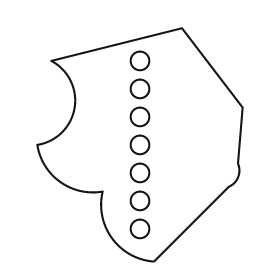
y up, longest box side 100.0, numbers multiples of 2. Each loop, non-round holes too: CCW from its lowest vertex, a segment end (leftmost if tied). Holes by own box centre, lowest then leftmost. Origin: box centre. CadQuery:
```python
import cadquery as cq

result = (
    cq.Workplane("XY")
    .moveTo(6.0, -50.0)
    .lineTo(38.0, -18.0)
    .threePointArc((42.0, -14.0), (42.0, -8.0))
    .lineTo(44.0, 16.0)
    .lineTo(18.0, 50.0)
    .lineTo(-38.0, 36.0)
    .threePointArc((-28.0, 16.0), (-44.0, 0.0))
    .threePointArc((-34.0, -16.0), (-16.0, -20.0))
    .threePointArc((-12.0, -40.0), (6.0, -50.0))
    .close()
    .moveTo(0.0, -36.0)
    .circle(4.0)
    .moveTo(0.0, -24.0)
    .circle(4.0)
    .moveTo(0.0, -12.0)
    .circle(4.0)
    .moveTo(0.0, 0.0)
    .circle(4.0)
    .moveTo(0.0, 12.0)
    .circle(4.0)
    .moveTo(0.0, 24.0)
    .circle(4.0)
    .moveTo(0.0, 36.0)
    .circle(4.0)
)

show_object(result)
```